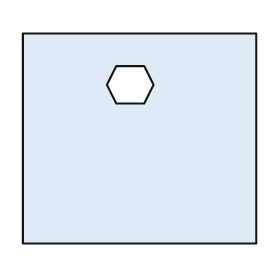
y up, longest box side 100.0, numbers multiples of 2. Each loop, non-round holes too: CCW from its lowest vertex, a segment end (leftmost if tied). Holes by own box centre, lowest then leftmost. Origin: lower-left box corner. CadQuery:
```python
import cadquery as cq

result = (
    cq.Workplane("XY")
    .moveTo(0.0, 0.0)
    .lineTo(100.0, 0.0)
    .lineTo(100.0, 90.0)
    .lineTo(0.0, 90.0)
    .close()
    .moveTo(40.0, 60.0)
    .lineTo(52.0, 60.0)
    .lineTo(56.0, 68.0)
    .lineTo(52.0, 76.0)
    .lineTo(40.0, 76.0)
    .lineTo(36.0, 68.0)
    .close()
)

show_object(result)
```